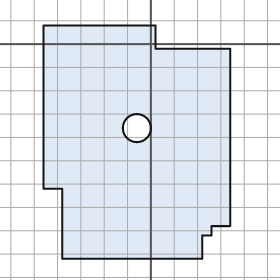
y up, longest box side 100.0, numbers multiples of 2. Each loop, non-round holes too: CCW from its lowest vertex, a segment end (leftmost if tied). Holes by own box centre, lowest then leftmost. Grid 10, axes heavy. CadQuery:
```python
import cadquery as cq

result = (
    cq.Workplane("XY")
    .moveTo(-38.0, -92.0)
    .lineTo(22.0, -92.0)
    .lineTo(22.0, -82.0)
    .lineTo(26.0, -82.0)
    .lineTo(26.0, -78.0)
    .lineTo(34.0, -78.0)
    .lineTo(34.0, -2.0)
    .lineTo(2.0, -2.0)
    .lineTo(2.0, 8.0)
    .lineTo(-46.0, 8.0)
    .lineTo(-46.0, -62.0)
    .lineTo(-38.0, -62.0)
    .close()
    .moveTo(-6.0, -36.0)
    .circle(6.0)
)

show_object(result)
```